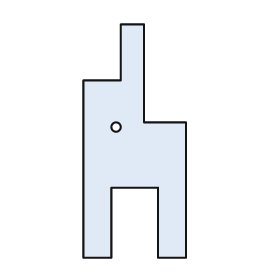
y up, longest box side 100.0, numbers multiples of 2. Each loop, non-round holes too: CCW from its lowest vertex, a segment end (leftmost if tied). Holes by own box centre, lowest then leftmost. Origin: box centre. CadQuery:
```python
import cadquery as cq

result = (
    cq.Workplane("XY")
    .moveTo(-22.0, -50.0)
    .lineTo(-10.0, -50.0)
    .lineTo(-10.0, -20.0)
    .lineTo(10.0, -20.0)
    .lineTo(10.0, -50.0)
    .lineTo(22.0, -50.0)
    .lineTo(22.0, 8.0)
    .lineTo(4.0, 8.0)
    .lineTo(4.0, 50.0)
    .lineTo(-6.0, 50.0)
    .lineTo(-6.0, 26.0)
    .lineTo(-22.0, 26.0)
    .close()
    .moveTo(-8.0, 6.0)
    .circle(2.0)
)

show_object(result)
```